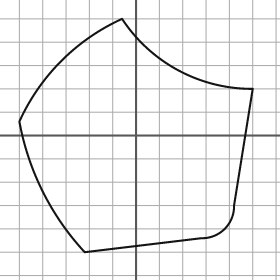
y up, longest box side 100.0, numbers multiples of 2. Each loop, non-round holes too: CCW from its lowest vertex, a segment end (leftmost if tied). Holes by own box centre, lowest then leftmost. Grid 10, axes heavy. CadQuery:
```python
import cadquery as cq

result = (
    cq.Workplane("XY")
    .moveTo(-22.0, -50.0)
    .lineTo(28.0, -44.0)
    .threePointArc((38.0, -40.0), (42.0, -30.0))
    .lineTo(50.0, 20.0)
    .threePointArc((18.0, 28.0), (-6.0, 50.0))
    .threePointArc((-32.0, 32.0), (-50.0, 6.0))
    .threePointArc((-40.0, -24.0), (-22.0, -50.0))
    .close()
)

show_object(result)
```